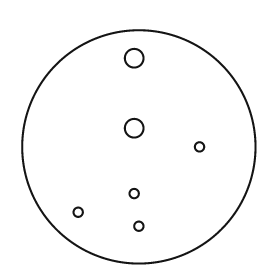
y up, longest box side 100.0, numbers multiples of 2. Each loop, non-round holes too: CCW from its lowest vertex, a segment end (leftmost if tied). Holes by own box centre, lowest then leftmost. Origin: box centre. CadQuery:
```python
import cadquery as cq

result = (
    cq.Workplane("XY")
    .moveTo(0.0, 0.0)
    .circle(50.0)
    .moveTo(0.0, -34.0)
    .circle(2.0)
    .moveTo(-26.0, -28.0)
    .circle(2.0)
    .moveTo(-2.0, -20.0)
    .circle(2.0)
    .moveTo(26.0, 0.0)
    .circle(2.0)
    .moveTo(-2.0, 8.0)
    .circle(4.0)
    .moveTo(-2.0, 38.0)
    .circle(4.0)
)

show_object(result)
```